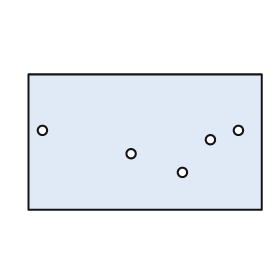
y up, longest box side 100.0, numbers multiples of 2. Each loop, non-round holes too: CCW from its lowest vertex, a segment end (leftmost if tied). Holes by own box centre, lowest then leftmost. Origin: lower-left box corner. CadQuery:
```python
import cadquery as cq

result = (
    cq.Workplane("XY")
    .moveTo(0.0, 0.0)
    .lineTo(100.0, 0.0)
    .lineTo(100.0, 58.0)
    .lineTo(0.0, 58.0)
    .close()
    .moveTo(66.0, 16.0)
    .circle(2.0)
    .moveTo(44.0, 24.0)
    .circle(2.0)
    .moveTo(78.0, 30.0)
    .circle(2.0)
    .moveTo(6.0, 34.0)
    .circle(2.0)
    .moveTo(90.0, 34.0)
    .circle(2.0)
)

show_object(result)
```